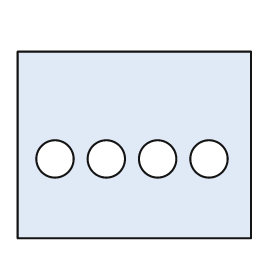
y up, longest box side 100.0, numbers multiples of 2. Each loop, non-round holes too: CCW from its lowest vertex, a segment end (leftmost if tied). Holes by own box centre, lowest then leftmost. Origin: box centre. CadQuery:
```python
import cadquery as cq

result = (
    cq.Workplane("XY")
    .moveTo(-50.0, -40.0)
    .lineTo(50.0, -40.0)
    .lineTo(50.0, 40.0)
    .lineTo(-50.0, 40.0)
    .close()
    .moveTo(-34.0, -6.0)
    .circle(8.0)
    .moveTo(-12.0, -6.0)
    .circle(8.0)
    .moveTo(10.0, -6.0)
    .circle(8.0)
    .moveTo(32.0, -6.0)
    .circle(8.0)
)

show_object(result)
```